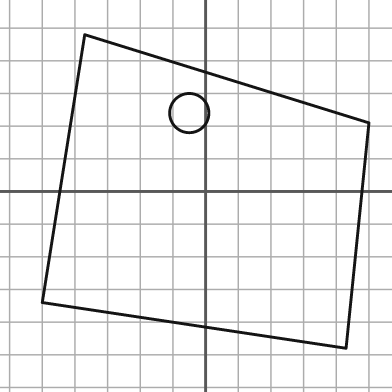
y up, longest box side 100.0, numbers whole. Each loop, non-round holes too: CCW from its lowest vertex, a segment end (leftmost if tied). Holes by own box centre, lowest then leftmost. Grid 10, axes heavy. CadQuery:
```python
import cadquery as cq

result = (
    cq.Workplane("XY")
    .moveTo(43.0, -48.0)
    .lineTo(50.0, 21.0)
    .lineTo(-37.0, 48.0)
    .lineTo(-50.0, -34.0)
    .close()
    .moveTo(-5.0, 24.0)
    .circle(6.0)
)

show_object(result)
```